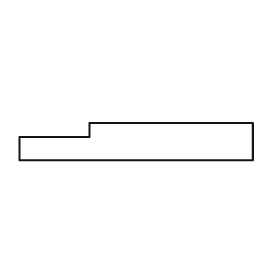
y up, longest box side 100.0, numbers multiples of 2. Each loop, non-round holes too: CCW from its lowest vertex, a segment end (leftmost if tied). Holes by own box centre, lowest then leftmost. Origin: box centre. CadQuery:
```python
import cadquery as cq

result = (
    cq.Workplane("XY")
    .moveTo(-50.0, -8.0)
    .lineTo(50.0, -8.0)
    .lineTo(50.0, 8.0)
    .lineTo(-20.0, 8.0)
    .lineTo(-20.0, 2.0)
    .lineTo(-50.0, 2.0)
    .close()
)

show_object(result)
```